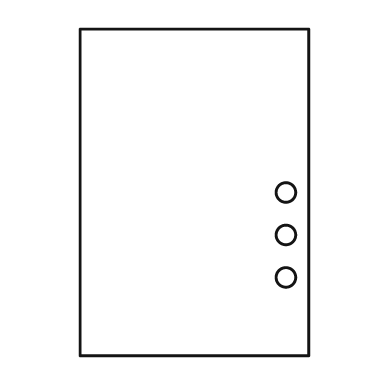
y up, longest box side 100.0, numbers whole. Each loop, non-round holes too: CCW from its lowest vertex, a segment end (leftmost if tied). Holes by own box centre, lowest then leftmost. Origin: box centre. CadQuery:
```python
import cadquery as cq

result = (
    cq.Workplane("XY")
    .moveTo(-35.0, -50.0)
    .lineTo(35.0, -50.0)
    .lineTo(35.0, 50.0)
    .lineTo(-35.0, 50.0)
    .close()
    .moveTo(28.0, -26.0)
    .circle(3.0)
    .moveTo(28.0, -13.0)
    .circle(3.0)
    .moveTo(28.0, 0.0)
    .circle(3.0)
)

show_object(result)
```